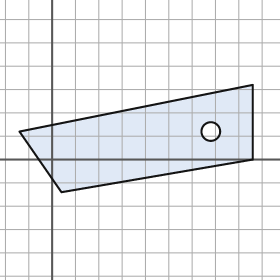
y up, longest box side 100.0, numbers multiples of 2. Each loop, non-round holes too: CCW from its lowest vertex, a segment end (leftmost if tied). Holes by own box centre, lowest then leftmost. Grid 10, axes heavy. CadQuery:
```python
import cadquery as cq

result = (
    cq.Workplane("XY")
    .moveTo(4.0, -14.0)
    .lineTo(86.0, 0.0)
    .lineTo(86.0, 32.0)
    .lineTo(-14.0, 12.0)
    .close()
    .moveTo(68.0, 12.0)
    .circle(4.0)
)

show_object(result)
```